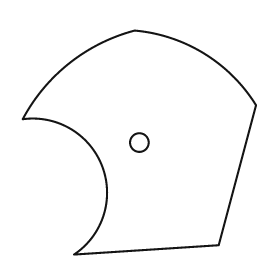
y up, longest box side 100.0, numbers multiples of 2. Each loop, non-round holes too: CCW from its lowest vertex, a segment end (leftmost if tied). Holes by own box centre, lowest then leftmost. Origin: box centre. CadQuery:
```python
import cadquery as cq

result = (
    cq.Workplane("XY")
    .moveTo(-28.0, -48.0)
    .lineTo(34.0, -44.0)
    .lineTo(50.0, 16.0)
    .threePointArc((28.0, 38.0), (-2.0, 48.0))
    .threePointArc((-30.0, 34.0), (-50.0, 10.0))
    .threePointArc((-16.0, -10.0), (-28.0, -48.0))
    .close()
    .moveTo(0.0, 0.0)
    .circle(4.0)
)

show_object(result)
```